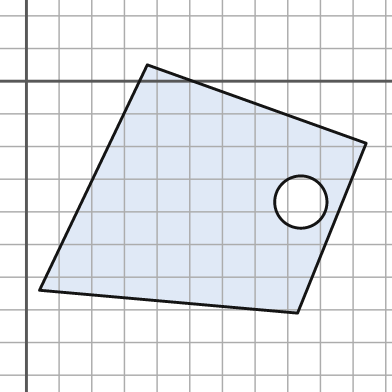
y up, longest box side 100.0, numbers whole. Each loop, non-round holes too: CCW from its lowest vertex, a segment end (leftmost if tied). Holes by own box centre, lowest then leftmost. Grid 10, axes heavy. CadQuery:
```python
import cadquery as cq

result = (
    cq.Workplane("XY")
    .moveTo(83.0, -71.0)
    .lineTo(104.0, -19.0)
    .lineTo(37.0, 5.0)
    .lineTo(4.0, -64.0)
    .close()
    .moveTo(84.0, -37.0)
    .circle(8.0)
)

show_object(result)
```